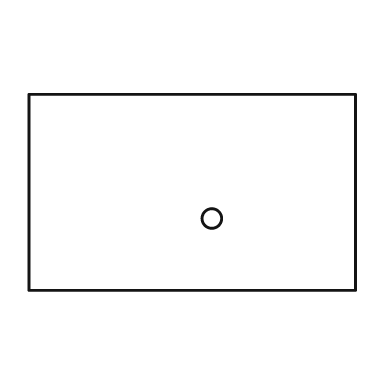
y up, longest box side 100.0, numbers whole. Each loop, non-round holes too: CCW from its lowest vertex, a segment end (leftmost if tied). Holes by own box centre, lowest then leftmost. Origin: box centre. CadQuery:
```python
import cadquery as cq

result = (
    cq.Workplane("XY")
    .moveTo(-50.0, -30.0)
    .lineTo(50.0, -30.0)
    .lineTo(50.0, 30.0)
    .lineTo(-50.0, 30.0)
    .close()
    .moveTo(6.0, -8.0)
    .circle(3.0)
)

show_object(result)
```